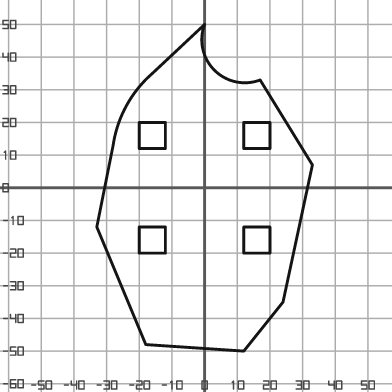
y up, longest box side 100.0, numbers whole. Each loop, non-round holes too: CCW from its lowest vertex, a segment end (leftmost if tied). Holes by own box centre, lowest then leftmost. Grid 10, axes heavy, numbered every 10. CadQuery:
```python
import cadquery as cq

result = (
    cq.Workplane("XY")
    .moveTo(12.0, -50.0)
    .lineTo(24.0, -35.0)
    .lineTo(33.0, 7.0)
    .lineTo(17.0, 33.0)
    .threePointArc((3.0, 36.0), (0.0, 50.0))
    .lineTo(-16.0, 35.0)
    .threePointArc((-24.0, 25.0), (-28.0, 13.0))
    .lineTo(-33.0, -12.0)
    .lineTo(-18.0, -48.0)
    .close()
    .moveTo(-20.0, -20.0)
    .lineTo(-12.0, -20.0)
    .lineTo(-12.0, -12.0)
    .lineTo(-20.0, -12.0)
    .close()
    .moveTo(12.0, -20.0)
    .lineTo(20.0, -20.0)
    .lineTo(20.0, -12.0)
    .lineTo(12.0, -12.0)
    .close()
    .moveTo(-20.0, 12.0)
    .lineTo(-12.0, 12.0)
    .lineTo(-12.0, 20.0)
    .lineTo(-20.0, 20.0)
    .close()
    .moveTo(12.0, 12.0)
    .lineTo(20.0, 12.0)
    .lineTo(20.0, 20.0)
    .lineTo(12.0, 20.0)
    .close()
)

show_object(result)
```